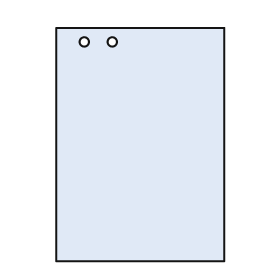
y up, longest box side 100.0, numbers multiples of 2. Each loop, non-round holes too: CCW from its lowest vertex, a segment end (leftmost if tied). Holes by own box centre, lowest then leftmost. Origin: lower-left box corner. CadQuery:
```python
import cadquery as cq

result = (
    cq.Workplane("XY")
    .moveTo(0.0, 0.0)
    .lineTo(72.0, 0.0)
    .lineTo(72.0, 100.0)
    .lineTo(0.0, 100.0)
    .close()
    .moveTo(12.0, 94.0)
    .circle(2.0)
    .moveTo(24.0, 94.0)
    .circle(2.0)
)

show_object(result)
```